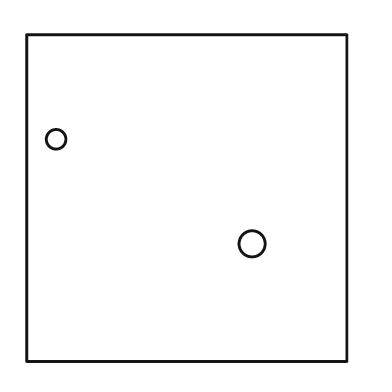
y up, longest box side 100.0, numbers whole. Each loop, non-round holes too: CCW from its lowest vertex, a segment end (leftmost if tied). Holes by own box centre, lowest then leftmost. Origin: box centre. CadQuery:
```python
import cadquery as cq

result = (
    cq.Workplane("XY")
    .moveTo(-49.0, -50.0)
    .lineTo(49.0, -50.0)
    .lineTo(49.0, 50.0)
    .lineTo(-49.0, 50.0)
    .close()
    .moveTo(20.0, -14.0)
    .circle(4.0)
    .moveTo(-40.0, 18.0)
    .circle(3.0)
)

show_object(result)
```